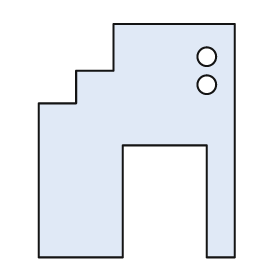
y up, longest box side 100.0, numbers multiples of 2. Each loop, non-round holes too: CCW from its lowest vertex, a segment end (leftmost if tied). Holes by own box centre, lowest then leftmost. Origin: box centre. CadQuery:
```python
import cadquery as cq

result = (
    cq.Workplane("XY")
    .moveTo(-42.0, -50.0)
    .lineTo(-6.0, -50.0)
    .lineTo(-6.0, -2.0)
    .lineTo(30.0, -2.0)
    .lineTo(30.0, -50.0)
    .lineTo(42.0, -50.0)
    .lineTo(42.0, 50.0)
    .lineTo(-10.0, 50.0)
    .lineTo(-10.0, 30.0)
    .lineTo(-26.0, 30.0)
    .lineTo(-26.0, 16.0)
    .lineTo(-42.0, 16.0)
    .close()
    .moveTo(30.0, 24.0)
    .circle(4.0)
    .moveTo(30.0, 36.0)
    .circle(4.0)
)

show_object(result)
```